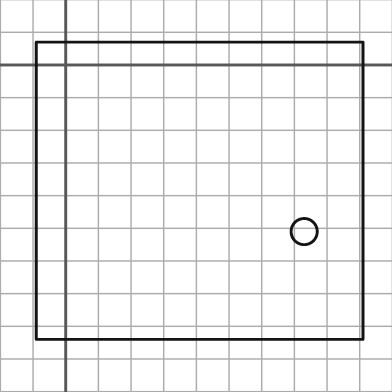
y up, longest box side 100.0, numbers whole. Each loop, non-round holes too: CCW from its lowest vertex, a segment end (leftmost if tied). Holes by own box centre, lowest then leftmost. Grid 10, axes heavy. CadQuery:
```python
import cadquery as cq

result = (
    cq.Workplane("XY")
    .moveTo(-9.0, -84.0)
    .lineTo(91.0, -84.0)
    .lineTo(91.0, 7.0)
    .lineTo(-9.0, 7.0)
    .close()
    .moveTo(73.0, -51.0)
    .circle(4.0)
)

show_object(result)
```